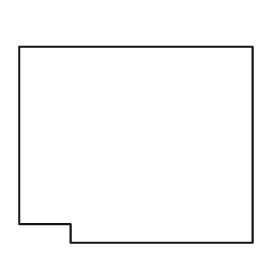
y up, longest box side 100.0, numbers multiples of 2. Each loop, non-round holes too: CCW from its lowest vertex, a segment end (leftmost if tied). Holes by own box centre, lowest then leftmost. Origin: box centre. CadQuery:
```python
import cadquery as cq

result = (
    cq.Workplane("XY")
    .moveTo(-28.0, -42.0)
    .lineTo(50.0, -42.0)
    .lineTo(50.0, 42.0)
    .lineTo(-50.0, 42.0)
    .lineTo(-50.0, -34.0)
    .lineTo(-28.0, -34.0)
    .close()
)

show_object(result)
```